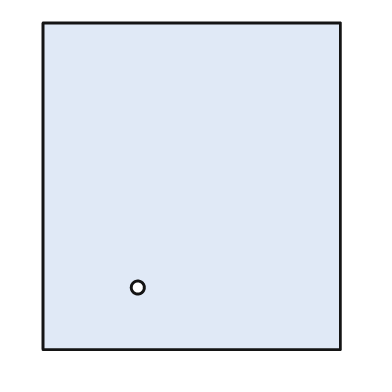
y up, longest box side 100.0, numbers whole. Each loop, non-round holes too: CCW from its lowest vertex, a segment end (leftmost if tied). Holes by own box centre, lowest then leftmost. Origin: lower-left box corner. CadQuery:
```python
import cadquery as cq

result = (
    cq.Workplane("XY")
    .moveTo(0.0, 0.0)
    .lineTo(91.0, 0.0)
    .lineTo(91.0, 100.0)
    .lineTo(0.0, 100.0)
    .close()
    .moveTo(29.0, 19.0)
    .circle(2.0)
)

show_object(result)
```